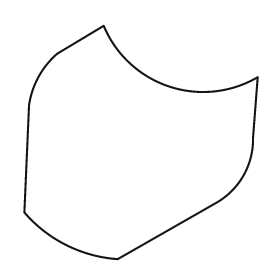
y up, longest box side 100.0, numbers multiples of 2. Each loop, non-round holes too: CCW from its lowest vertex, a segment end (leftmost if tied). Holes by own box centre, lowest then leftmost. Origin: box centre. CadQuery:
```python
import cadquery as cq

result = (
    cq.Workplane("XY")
    .moveTo(-10.0, -50.0)
    .lineTo(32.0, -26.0)
    .threePointArc((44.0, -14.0), (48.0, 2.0))
    .lineTo(50.0, 28.0)
    .threePointArc((12.0, 24.0), (-16.0, 50.0))
    .lineTo(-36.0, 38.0)
    .threePointArc((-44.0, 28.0), (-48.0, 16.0))
    .lineTo(-50.0, -30.0)
    .threePointArc((-32.0, -44.0), (-10.0, -50.0))
    .close()
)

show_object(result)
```